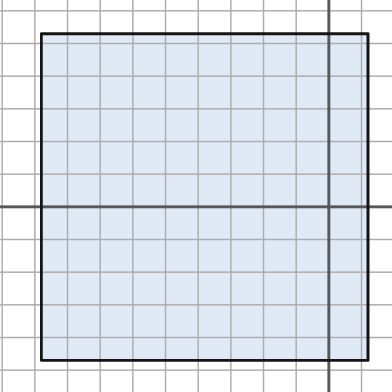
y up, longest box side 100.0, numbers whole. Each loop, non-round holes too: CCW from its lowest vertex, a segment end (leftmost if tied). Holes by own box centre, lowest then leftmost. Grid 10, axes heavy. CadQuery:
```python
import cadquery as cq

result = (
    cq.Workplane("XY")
    .moveTo(-88.0, -47.0)
    .lineTo(12.0, -47.0)
    .lineTo(12.0, 53.0)
    .lineTo(-88.0, 53.0)
    .close()
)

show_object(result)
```